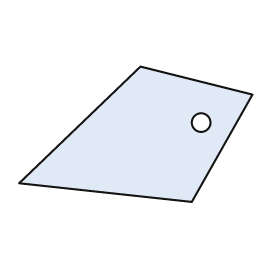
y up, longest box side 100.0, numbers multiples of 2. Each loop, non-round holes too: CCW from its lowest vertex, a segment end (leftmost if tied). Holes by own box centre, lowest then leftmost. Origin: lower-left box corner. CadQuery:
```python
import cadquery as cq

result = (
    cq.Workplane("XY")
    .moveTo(74.0, 0.0)
    .lineTo(100.0, 46.0)
    .lineTo(52.0, 58.0)
    .lineTo(0.0, 8.0)
    .close()
    .moveTo(78.0, 34.0)
    .circle(4.0)
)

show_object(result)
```